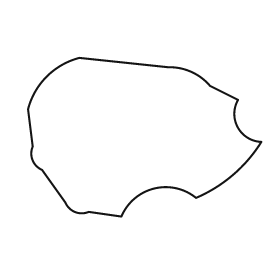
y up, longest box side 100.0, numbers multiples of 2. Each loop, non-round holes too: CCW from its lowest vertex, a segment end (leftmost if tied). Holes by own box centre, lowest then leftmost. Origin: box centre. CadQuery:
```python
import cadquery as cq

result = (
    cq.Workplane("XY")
    .moveTo(-10.0, -34.0)
    .threePointArc((4.0, -22.0), (22.0, -26.0))
    .threePointArc((38.0, -16.0), (50.0, -2.0))
    .threePointArc((40.0, 4.0), (40.0, 16.0))
    .lineTo(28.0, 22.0)
    .threePointArc((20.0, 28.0), (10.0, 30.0))
    .lineTo(-28.0, 34.0)
    .threePointArc((-42.0, 26.0), (-50.0, 12.0))
    .lineTo(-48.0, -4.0)
    .threePointArc((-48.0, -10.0), (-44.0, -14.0))
    .lineTo(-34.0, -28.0)
    .threePointArc((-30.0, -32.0), (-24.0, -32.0))
    .close()
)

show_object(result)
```